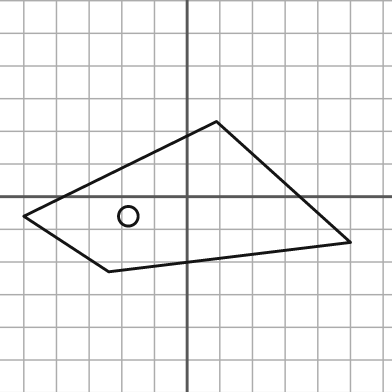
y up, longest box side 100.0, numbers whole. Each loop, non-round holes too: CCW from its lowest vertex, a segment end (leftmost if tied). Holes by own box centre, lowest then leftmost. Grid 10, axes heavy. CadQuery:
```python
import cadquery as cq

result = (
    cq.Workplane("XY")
    .moveTo(-24.0, -23.0)
    .lineTo(50.0, -14.0)
    .lineTo(9.0, 23.0)
    .lineTo(-50.0, -6.0)
    .close()
    .moveTo(-18.0, -6.0)
    .circle(3.0)
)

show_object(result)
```